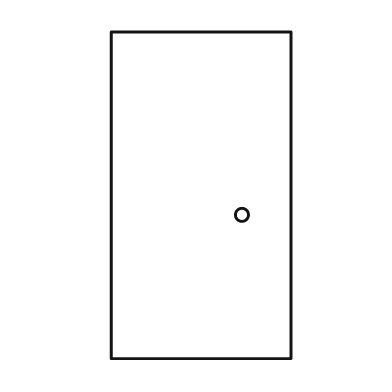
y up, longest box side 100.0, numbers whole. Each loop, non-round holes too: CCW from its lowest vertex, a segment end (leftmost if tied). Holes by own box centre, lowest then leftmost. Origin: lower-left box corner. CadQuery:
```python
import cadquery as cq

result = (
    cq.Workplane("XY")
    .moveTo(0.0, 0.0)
    .lineTo(55.0, 0.0)
    .lineTo(55.0, 100.0)
    .lineTo(0.0, 100.0)
    .close()
    .moveTo(40.0, 44.0)
    .circle(2.0)
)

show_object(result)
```